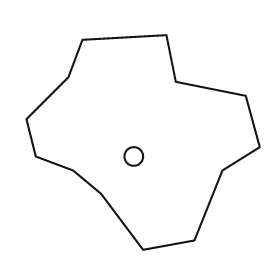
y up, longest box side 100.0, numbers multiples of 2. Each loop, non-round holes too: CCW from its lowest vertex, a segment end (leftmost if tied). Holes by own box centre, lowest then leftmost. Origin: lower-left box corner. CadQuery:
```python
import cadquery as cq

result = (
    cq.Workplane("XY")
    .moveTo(50.0, 0.0)
    .lineTo(72.0, 4.0)
    .lineTo(84.0, 34.0)
    .lineTo(100.0, 44.0)
    .lineTo(94.0, 66.0)
    .lineTo(64.0, 72.0)
    .lineTo(60.0, 92.0)
    .lineTo(24.0, 90.0)
    .lineTo(18.0, 74.0)
    .lineTo(0.0, 56.0)
    .lineTo(4.0, 40.0)
    .lineTo(20.0, 34.0)
    .lineTo(32.0, 24.0)
    .close()
    .moveTo(46.0, 40.0)
    .circle(4.0)
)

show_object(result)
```